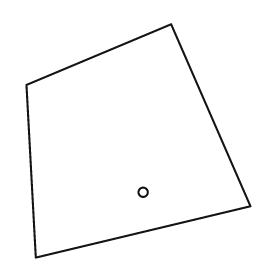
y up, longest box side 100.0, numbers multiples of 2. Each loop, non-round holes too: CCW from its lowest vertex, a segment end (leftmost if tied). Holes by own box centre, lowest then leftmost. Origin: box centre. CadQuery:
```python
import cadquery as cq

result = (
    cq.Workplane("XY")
    .moveTo(-44.0, -50.0)
    .lineTo(48.0, -28.0)
    .lineTo(14.0, 50.0)
    .lineTo(-48.0, 24.0)
    .close()
    .moveTo(2.0, -22.0)
    .circle(2.0)
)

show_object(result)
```